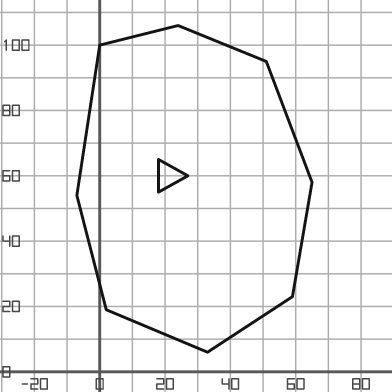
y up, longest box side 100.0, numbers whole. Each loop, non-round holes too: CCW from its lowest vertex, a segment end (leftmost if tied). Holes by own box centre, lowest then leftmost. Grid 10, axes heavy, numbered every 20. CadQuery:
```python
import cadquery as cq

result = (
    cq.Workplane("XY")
    .moveTo(33.0, 6.0)
    .lineTo(59.0, 23.0)
    .lineTo(65.0, 58.0)
    .lineTo(51.0, 95.0)
    .lineTo(24.0, 106.0)
    .lineTo(0.0, 100.0)
    .lineTo(-7.0, 54.0)
    .lineTo(2.0, 19.0)
    .close()
    .moveTo(18.0, 55.0)
    .lineTo(27.0, 60.0)
    .lineTo(18.0, 65.0)
    .close()
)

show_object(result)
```